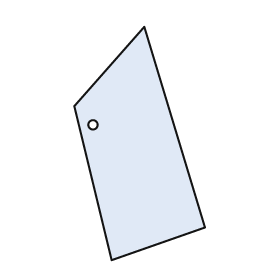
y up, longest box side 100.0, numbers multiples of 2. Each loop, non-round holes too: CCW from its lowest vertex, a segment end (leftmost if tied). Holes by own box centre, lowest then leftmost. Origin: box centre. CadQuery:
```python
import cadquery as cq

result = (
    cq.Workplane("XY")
    .moveTo(-12.0, -50.0)
    .lineTo(28.0, -36.0)
    .lineTo(2.0, 50.0)
    .lineTo(-28.0, 16.0)
    .close()
    .moveTo(-20.0, 8.0)
    .circle(2.0)
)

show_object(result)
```